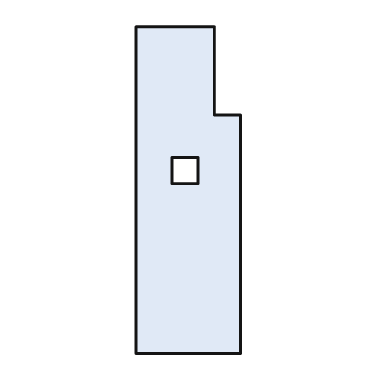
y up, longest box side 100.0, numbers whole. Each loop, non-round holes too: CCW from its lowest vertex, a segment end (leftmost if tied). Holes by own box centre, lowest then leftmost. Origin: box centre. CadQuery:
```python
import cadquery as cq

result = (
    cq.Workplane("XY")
    .moveTo(-16.0, -50.0)
    .lineTo(16.0, -50.0)
    .lineTo(16.0, 23.0)
    .lineTo(8.0, 23.0)
    .lineTo(8.0, 50.0)
    .lineTo(-16.0, 50.0)
    .close()
    .moveTo(-5.0, 2.0)
    .lineTo(3.0, 2.0)
    .lineTo(3.0, 10.0)
    .lineTo(-5.0, 10.0)
    .close()
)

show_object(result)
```